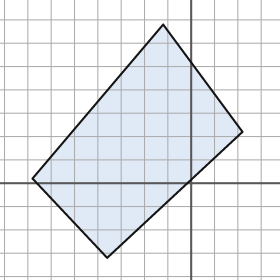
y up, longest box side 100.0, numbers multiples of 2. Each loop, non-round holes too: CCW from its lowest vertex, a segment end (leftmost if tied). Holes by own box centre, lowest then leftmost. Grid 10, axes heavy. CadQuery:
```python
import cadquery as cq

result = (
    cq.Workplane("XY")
    .moveTo(-36.0, -32.0)
    .lineTo(22.0, 22.0)
    .lineTo(-12.0, 68.0)
    .lineTo(-68.0, 2.0)
    .close()
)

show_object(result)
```